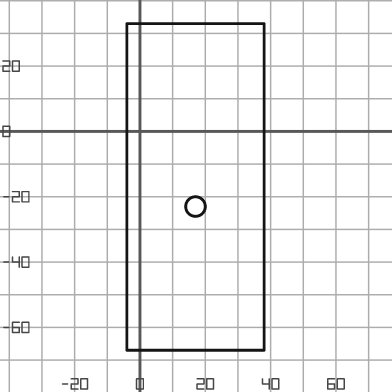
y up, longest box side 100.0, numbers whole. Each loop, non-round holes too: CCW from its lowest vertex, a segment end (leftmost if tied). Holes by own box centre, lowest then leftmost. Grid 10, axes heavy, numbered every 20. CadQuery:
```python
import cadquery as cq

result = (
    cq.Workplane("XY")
    .moveTo(-4.0, -67.0)
    .lineTo(38.0, -67.0)
    .lineTo(38.0, 33.0)
    .lineTo(-4.0, 33.0)
    .close()
    .moveTo(17.0, -23.0)
    .circle(3.0)
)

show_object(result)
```